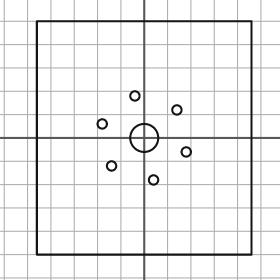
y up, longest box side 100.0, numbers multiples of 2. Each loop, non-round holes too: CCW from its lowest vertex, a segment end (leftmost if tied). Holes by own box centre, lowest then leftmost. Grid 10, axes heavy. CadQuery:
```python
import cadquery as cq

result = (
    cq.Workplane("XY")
    .moveTo(-46.0, -50.0)
    .lineTo(46.0, -50.0)
    .lineTo(46.0, 50.0)
    .lineTo(-46.0, 50.0)
    .close()
    .moveTo(4.0, -18.0)
    .circle(2.0)
    .moveTo(-14.0, -12.0)
    .circle(2.0)
    .moveTo(18.0, -6.0)
    .circle(2.0)
    .moveTo(0.0, 0.0)
    .circle(6.0)
    .moveTo(-18.0, 6.0)
    .circle(2.0)
    .moveTo(14.0, 12.0)
    .circle(2.0)
    .moveTo(-4.0, 18.0)
    .circle(2.0)
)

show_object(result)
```